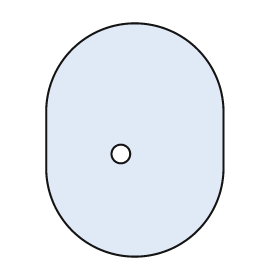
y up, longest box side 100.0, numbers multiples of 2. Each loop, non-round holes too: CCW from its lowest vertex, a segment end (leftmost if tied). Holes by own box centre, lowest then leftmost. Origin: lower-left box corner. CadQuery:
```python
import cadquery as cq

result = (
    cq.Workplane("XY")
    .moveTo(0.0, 38.0)
    .threePointArc((38.0, 0.0), (76.0, 38.0))
    .lineTo(76.0, 62.0)
    .threePointArc((38.0, 100.0), (0.0, 62.0))
    .close()
    .moveTo(32.0, 44.0)
    .circle(4.0)
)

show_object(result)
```